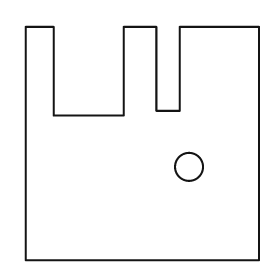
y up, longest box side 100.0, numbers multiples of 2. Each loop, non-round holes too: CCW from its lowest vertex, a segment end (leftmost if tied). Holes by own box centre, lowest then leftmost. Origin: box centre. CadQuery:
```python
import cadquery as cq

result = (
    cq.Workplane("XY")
    .moveTo(-50.0, -50.0)
    .lineTo(50.0, -50.0)
    .lineTo(50.0, 50.0)
    .lineTo(16.0, 50.0)
    .lineTo(16.0, 14.0)
    .lineTo(6.0, 14.0)
    .lineTo(6.0, 50.0)
    .lineTo(-8.0, 50.0)
    .lineTo(-8.0, 12.0)
    .lineTo(-38.0, 12.0)
    .lineTo(-38.0, 50.0)
    .lineTo(-50.0, 50.0)
    .close()
    .moveTo(20.0, -10.0)
    .circle(6.0)
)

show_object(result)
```